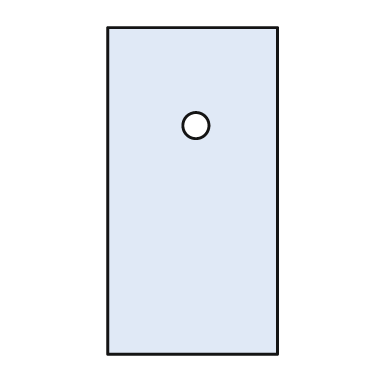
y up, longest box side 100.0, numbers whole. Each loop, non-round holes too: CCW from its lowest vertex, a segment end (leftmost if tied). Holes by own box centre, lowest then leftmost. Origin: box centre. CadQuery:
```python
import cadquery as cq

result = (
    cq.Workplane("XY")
    .moveTo(-26.0, -50.0)
    .lineTo(26.0, -50.0)
    .lineTo(26.0, 50.0)
    .lineTo(-26.0, 50.0)
    .close()
    .moveTo(1.0, 20.0)
    .circle(4.0)
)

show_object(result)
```